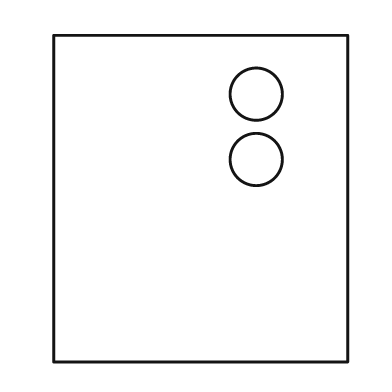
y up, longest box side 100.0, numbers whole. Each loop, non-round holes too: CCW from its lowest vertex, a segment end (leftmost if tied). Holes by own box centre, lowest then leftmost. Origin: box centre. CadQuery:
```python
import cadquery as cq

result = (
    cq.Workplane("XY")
    .moveTo(-45.0, -50.0)
    .lineTo(45.0, -50.0)
    .lineTo(45.0, 50.0)
    .lineTo(-45.0, 50.0)
    .close()
    .moveTo(17.0, 12.0)
    .circle(8.0)
    .moveTo(17.0, 32.0)
    .circle(8.0)
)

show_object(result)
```